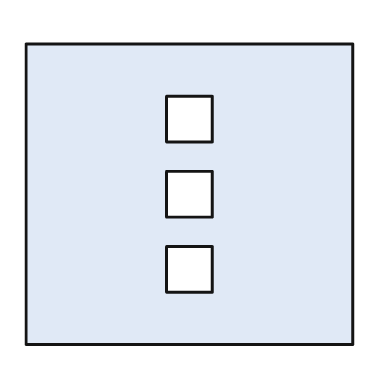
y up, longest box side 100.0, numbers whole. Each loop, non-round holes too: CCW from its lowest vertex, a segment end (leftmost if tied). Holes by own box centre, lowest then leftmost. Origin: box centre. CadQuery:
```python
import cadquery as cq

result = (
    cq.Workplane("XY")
    .moveTo(-50.0, -46.0)
    .lineTo(50.0, -46.0)
    .lineTo(50.0, 46.0)
    .lineTo(-50.0, 46.0)
    .close()
    .moveTo(-7.0, -30.0)
    .lineTo(7.0, -30.0)
    .lineTo(7.0, -16.0)
    .lineTo(-7.0, -16.0)
    .close()
    .moveTo(-7.0, -7.0)
    .lineTo(7.0, -7.0)
    .lineTo(7.0, 7.0)
    .lineTo(-7.0, 7.0)
    .close()
    .moveTo(-7.0, 16.0)
    .lineTo(7.0, 16.0)
    .lineTo(7.0, 30.0)
    .lineTo(-7.0, 30.0)
    .close()
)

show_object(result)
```